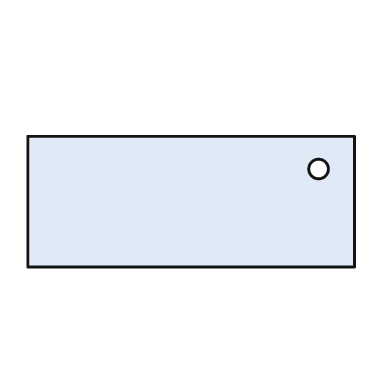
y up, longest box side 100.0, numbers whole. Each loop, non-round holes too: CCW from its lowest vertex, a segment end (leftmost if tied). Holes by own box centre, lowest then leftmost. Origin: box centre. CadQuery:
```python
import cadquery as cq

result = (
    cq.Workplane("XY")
    .moveTo(-50.0, -20.0)
    .lineTo(50.0, -20.0)
    .lineTo(50.0, 20.0)
    .lineTo(-50.0, 20.0)
    .close()
    .moveTo(39.0, 10.0)
    .circle(3.0)
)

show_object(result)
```